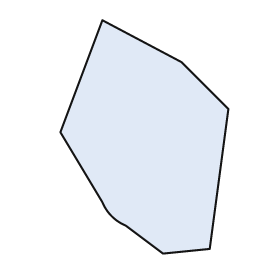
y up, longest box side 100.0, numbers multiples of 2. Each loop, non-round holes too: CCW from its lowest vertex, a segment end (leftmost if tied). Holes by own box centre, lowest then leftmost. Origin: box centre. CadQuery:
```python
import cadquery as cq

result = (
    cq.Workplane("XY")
    .moveTo(8.0, -50.0)
    .lineTo(28.0, -48.0)
    .lineTo(36.0, 12.0)
    .lineTo(16.0, 32.0)
    .lineTo(-18.0, 50.0)
    .lineTo(-36.0, 2.0)
    .lineTo(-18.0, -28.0)
    .threePointArc((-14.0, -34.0), (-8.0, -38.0))
    .close()
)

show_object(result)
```